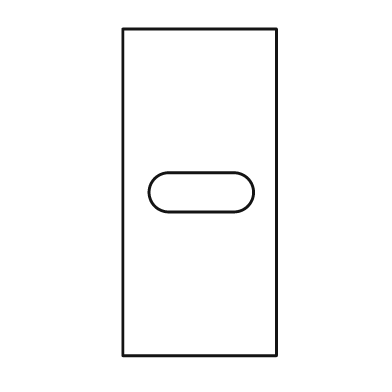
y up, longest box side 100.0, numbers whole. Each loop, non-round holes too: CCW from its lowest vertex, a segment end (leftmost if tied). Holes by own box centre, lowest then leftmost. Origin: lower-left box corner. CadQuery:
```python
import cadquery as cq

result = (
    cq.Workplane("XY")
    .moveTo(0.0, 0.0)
    .lineTo(47.0, 0.0)
    .lineTo(47.0, 100.0)
    .lineTo(0.0, 100.0)
    .close()
    .moveTo(14.0, 44.0)
    .lineTo(34.0, 44.0)
    .threePointArc((40.0, 50.0), (34.0, 56.0))
    .lineTo(14.0, 56.0)
    .threePointArc((8.0, 50.0), (14.0, 44.0))
    .close()
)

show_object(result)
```